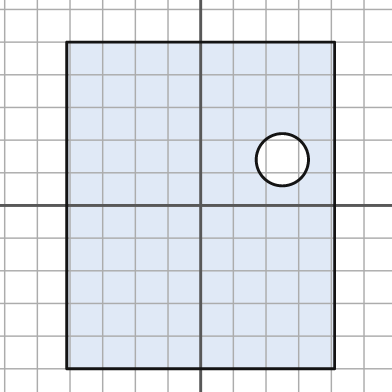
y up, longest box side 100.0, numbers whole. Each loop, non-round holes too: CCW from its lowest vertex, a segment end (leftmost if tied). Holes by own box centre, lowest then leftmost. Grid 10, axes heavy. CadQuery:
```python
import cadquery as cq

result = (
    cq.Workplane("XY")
    .moveTo(-41.0, -50.0)
    .lineTo(41.0, -50.0)
    .lineTo(41.0, 50.0)
    .lineTo(-41.0, 50.0)
    .close()
    .moveTo(25.0, 14.0)
    .circle(8.0)
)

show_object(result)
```